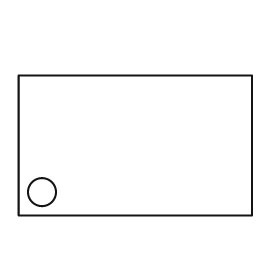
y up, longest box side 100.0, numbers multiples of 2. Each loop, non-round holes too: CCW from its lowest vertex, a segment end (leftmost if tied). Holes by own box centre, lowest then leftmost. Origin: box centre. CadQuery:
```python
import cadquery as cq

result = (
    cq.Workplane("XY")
    .moveTo(-50.0, -30.0)
    .lineTo(50.0, -30.0)
    .lineTo(50.0, 30.0)
    .lineTo(-50.0, 30.0)
    .close()
    .moveTo(-40.0, -20.0)
    .circle(6.0)
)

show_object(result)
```